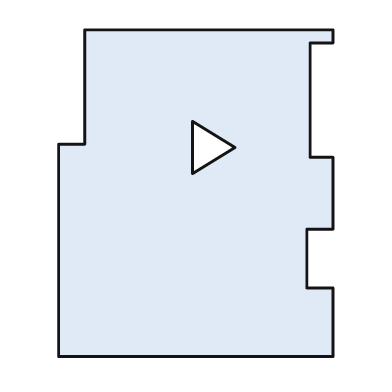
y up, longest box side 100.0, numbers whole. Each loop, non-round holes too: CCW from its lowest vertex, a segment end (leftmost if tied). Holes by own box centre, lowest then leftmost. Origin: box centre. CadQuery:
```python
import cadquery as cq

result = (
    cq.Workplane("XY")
    .moveTo(-42.0, -50.0)
    .lineTo(42.0, -50.0)
    .lineTo(42.0, -29.0)
    .lineTo(34.0, -29.0)
    .lineTo(34.0, -11.0)
    .lineTo(42.0, -11.0)
    .lineTo(42.0, 11.0)
    .lineTo(35.0, 11.0)
    .lineTo(35.0, 46.0)
    .lineTo(42.0, 46.0)
    .lineTo(42.0, 50.0)
    .lineTo(-34.0, 50.0)
    .lineTo(-34.0, 15.0)
    .lineTo(-42.0, 15.0)
    .close()
    .moveTo(-1.0, 6.0)
    .lineTo(12.0, 14.0)
    .lineTo(-1.0, 22.0)
    .close()
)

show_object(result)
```